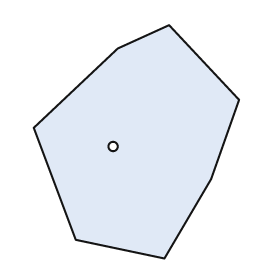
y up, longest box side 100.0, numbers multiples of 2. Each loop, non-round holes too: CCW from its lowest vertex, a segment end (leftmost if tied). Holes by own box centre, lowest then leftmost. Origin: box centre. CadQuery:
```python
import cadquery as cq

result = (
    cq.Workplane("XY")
    .moveTo(12.0, -50.0)
    .lineTo(32.0, -16.0)
    .lineTo(44.0, 18.0)
    .lineTo(14.0, 50.0)
    .lineTo(-8.0, 40.0)
    .lineTo(-44.0, 6.0)
    .lineTo(-26.0, -42.0)
    .close()
    .moveTo(-10.0, -2.0)
    .circle(2.0)
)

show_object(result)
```